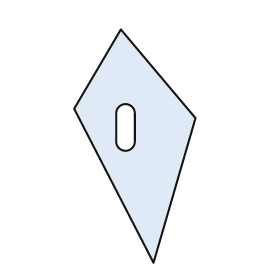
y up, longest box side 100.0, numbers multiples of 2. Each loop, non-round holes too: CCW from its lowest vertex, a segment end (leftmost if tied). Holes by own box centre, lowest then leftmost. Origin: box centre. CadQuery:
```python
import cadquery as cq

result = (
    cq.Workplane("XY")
    .moveTo(8.0, -50.0)
    .lineTo(26.0, 12.0)
    .lineTo(-6.0, 50.0)
    .lineTo(-26.0, 16.0)
    .close()
    .moveTo(-8.0, 2.0)
    .threePointArc((-4.0, -2.0), (0.0, 2.0))
    .lineTo(0.0, 14.0)
    .threePointArc((-4.0, 18.0), (-8.0, 14.0))
    .close()
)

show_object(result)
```